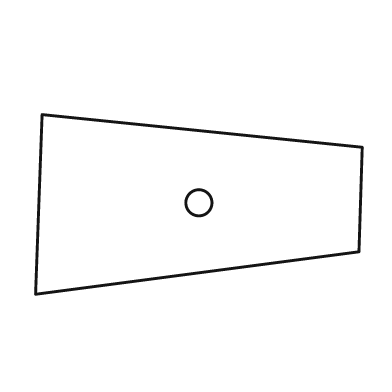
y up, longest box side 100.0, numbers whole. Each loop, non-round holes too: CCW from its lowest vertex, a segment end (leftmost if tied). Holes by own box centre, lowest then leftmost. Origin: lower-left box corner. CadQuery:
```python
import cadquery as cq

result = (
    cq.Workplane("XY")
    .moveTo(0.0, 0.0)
    .lineTo(99.0, 13.0)
    .lineTo(100.0, 45.0)
    .lineTo(2.0, 55.0)
    .close()
    .moveTo(50.0, 28.0)
    .circle(4.0)
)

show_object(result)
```